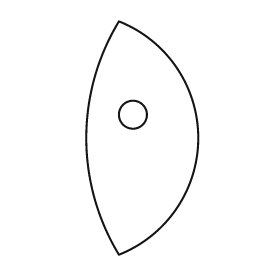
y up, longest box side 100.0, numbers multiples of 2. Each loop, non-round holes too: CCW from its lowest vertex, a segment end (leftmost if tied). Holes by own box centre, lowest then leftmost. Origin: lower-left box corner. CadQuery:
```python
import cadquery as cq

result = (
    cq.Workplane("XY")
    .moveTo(14.0, 0.0)
    .threePointArc((48.0, 50.0), (14.0, 100.0))
    .threePointArc((0.0, 50.0), (14.0, 0.0))
    .close()
    .moveTo(20.0, 60.0)
    .circle(6.0)
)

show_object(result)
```